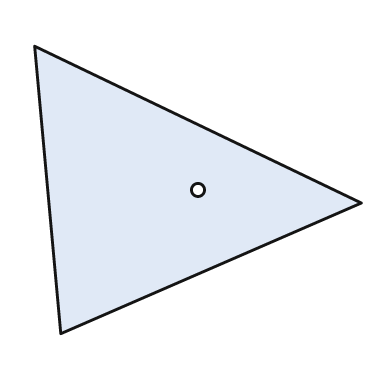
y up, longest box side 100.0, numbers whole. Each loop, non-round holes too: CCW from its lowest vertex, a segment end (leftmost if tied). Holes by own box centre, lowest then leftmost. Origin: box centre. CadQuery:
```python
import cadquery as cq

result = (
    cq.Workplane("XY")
    .moveTo(-42.0, -44.0)
    .lineTo(50.0, -4.0)
    .lineTo(-50.0, 44.0)
    .close()
    .moveTo(0.0, 0.0)
    .circle(2.0)
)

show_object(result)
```